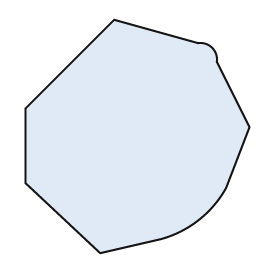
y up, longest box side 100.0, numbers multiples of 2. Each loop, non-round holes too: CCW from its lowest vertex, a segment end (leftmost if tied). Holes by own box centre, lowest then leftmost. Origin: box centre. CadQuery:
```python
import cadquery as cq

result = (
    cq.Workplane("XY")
    .moveTo(-16.0, -50.0)
    .lineTo(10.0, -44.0)
    .threePointArc((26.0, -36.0), (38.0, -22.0))
    .lineTo(48.0, 4.0)
    .lineTo(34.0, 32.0)
    .threePointArc((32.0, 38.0), (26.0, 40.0))
    .lineTo(-10.0, 50.0)
    .lineTo(-48.0, 12.0)
    .lineTo(-48.0, -20.0)
    .close()
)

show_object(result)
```